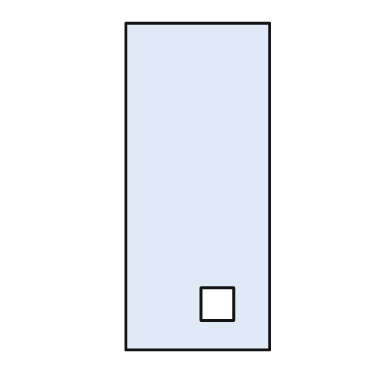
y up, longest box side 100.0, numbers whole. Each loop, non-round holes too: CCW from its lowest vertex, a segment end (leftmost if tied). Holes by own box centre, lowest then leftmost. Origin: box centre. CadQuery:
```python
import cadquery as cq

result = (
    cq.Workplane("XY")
    .moveTo(-22.0, -50.0)
    .lineTo(22.0, -50.0)
    .lineTo(22.0, 50.0)
    .lineTo(-22.0, 50.0)
    .close()
    .moveTo(1.0, -41.0)
    .lineTo(11.0, -41.0)
    .lineTo(11.0, -31.0)
    .lineTo(1.0, -31.0)
    .close()
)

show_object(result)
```